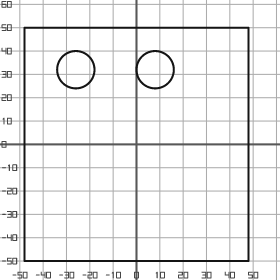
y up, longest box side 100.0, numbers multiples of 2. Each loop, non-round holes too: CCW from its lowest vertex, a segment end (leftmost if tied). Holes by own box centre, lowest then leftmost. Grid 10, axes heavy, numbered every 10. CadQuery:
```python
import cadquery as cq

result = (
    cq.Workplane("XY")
    .moveTo(-48.0, -50.0)
    .lineTo(48.0, -50.0)
    .lineTo(48.0, 50.0)
    .lineTo(-48.0, 50.0)
    .close()
    .moveTo(-26.0, 32.0)
    .circle(8.0)
    .moveTo(8.0, 32.0)
    .circle(8.0)
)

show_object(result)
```